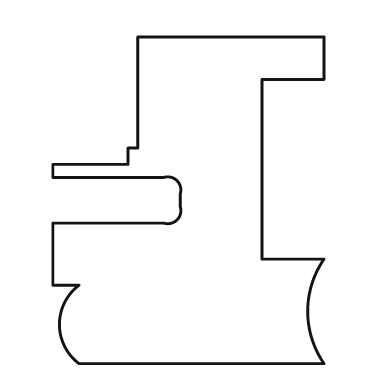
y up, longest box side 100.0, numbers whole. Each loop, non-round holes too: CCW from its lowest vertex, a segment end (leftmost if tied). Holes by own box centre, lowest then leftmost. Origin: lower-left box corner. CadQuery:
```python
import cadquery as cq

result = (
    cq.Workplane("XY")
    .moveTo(8.0, 0.0)
    .lineTo(83.0, 0.0)
    .threePointArc((78.0, 16.0), (83.0, 32.0))
    .lineTo(64.0, 32.0)
    .lineTo(64.0, 87.0)
    .lineTo(83.0, 87.0)
    .lineTo(83.0, 100.0)
    .lineTo(26.0, 100.0)
    .lineTo(26.0, 66.0)
    .lineTo(23.0, 66.0)
    .lineTo(23.0, 61.0)
    .lineTo(0.0, 61.0)
    .lineTo(0.0, 57.0)
    .lineTo(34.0, 57.0)
    .threePointArc((38.0, 56.0), (39.0, 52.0))
    .lineTo(39.0, 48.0)
    .threePointArc((38.0, 44.0), (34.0, 43.0))
    .lineTo(0.0, 43.0)
    .lineTo(0.0, 24.0)
    .lineTo(8.0, 24.0)
    .threePointArc((2.0, 12.0), (8.0, 0.0))
    .close()
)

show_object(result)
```